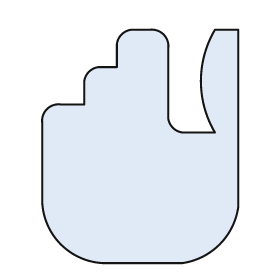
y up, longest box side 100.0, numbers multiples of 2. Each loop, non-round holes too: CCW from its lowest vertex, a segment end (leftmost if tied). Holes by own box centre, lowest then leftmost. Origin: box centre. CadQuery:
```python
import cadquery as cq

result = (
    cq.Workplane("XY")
    .moveTo(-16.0, -50.0)
    .lineTo(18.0, -50.0)
    .threePointArc((34.0, -42.0), (42.0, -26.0))
    .lineTo(42.0, 50.0)
    .lineTo(32.0, 50.0)
    .threePointArc((26.0, 28.0), (32.0, 6.0))
    .lineTo(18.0, 6.0)
    .threePointArc((14.0, 8.0), (12.0, 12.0))
    .lineTo(12.0, 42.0)
    .threePointArc((10.0, 48.0), (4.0, 50.0))
    .lineTo(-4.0, 50.0)
    .threePointArc((-8.0, 48.0), (-10.0, 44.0))
    .lineTo(-10.0, 34.0)
    .lineTo(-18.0, 34.0)
    .threePointArc((-22.0, 32.0), (-24.0, 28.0))
    .lineTo(-24.0, 18.0)
    .lineTo(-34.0, 18.0)
    .threePointArc((-40.0, 16.0), (-42.0, 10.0))
    .lineTo(-42.0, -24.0)
    .threePointArc((-34.0, -42.0), (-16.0, -50.0))
    .close()
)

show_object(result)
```